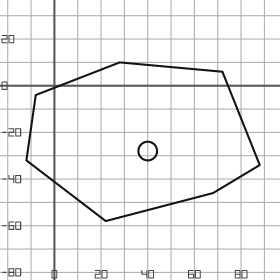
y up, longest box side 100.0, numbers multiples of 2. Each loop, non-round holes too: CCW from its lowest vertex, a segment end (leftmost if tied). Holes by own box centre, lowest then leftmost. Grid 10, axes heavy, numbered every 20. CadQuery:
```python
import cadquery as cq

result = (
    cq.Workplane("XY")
    .moveTo(22.0, -58.0)
    .lineTo(68.0, -46.0)
    .lineTo(88.0, -34.0)
    .lineTo(72.0, 6.0)
    .lineTo(28.0, 10.0)
    .lineTo(-8.0, -4.0)
    .lineTo(-12.0, -32.0)
    .close()
    .moveTo(40.0, -28.0)
    .circle(4.0)
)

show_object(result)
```